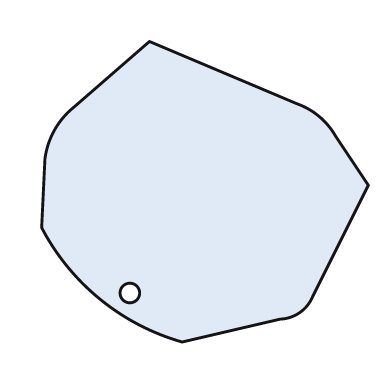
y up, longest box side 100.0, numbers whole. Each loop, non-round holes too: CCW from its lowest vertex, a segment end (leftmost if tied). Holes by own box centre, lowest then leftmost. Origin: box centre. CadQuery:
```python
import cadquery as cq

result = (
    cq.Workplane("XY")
    .moveTo(-7.0, -46.0)
    .lineTo(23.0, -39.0)
    .threePointArc((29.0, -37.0), (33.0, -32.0))
    .lineTo(50.0, 2.0)
    .lineTo(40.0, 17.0)
    .threePointArc((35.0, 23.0), (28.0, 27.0))
    .lineTo(-17.0, 46.0)
    .lineTo(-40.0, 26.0)
    .threePointArc((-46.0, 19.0), (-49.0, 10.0))
    .lineTo(-50.0, -11.0)
    .threePointArc((-32.0, -33.0), (-7.0, -46.0))
    .close()
    .moveTo(-23.0, -31.0)
    .circle(3.0)
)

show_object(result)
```